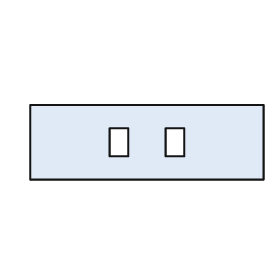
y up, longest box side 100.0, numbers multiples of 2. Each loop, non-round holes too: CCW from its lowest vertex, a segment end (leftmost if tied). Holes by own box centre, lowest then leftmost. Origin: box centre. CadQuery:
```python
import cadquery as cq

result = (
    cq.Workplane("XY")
    .moveTo(-50.0, -16.0)
    .lineTo(50.0, -16.0)
    .lineTo(50.0, 16.0)
    .lineTo(-50.0, 16.0)
    .close()
    .moveTo(-16.0, -6.0)
    .lineTo(-8.0, -6.0)
    .lineTo(-8.0, 6.0)
    .lineTo(-16.0, 6.0)
    .close()
    .moveTo(8.0, -6.0)
    .lineTo(16.0, -6.0)
    .lineTo(16.0, 6.0)
    .lineTo(8.0, 6.0)
    .close()
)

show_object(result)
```